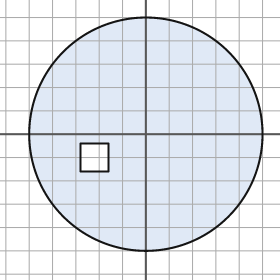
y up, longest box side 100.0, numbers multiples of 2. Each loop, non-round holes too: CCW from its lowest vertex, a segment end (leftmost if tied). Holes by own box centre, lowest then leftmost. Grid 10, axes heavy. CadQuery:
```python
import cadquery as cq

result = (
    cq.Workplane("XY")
    .moveTo(0.0, 0.0)
    .circle(50.0)
    .moveTo(-28.0, -16.0)
    .lineTo(-16.0, -16.0)
    .lineTo(-16.0, -4.0)
    .lineTo(-28.0, -4.0)
    .close()
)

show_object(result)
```